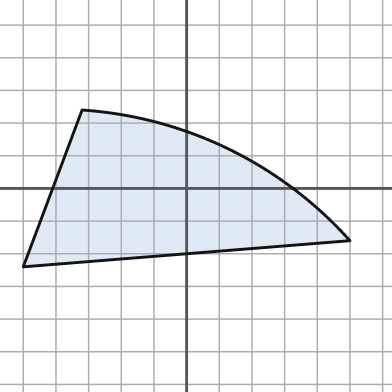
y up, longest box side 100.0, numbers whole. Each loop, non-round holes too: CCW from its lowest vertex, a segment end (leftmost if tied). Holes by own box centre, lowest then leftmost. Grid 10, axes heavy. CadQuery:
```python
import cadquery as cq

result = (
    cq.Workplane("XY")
    .moveTo(-50.0, -24.0)
    .lineTo(50.0, -16.0)
    .threePointArc((13.0, 12.0), (-32.0, 24.0))
    .close()
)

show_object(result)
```